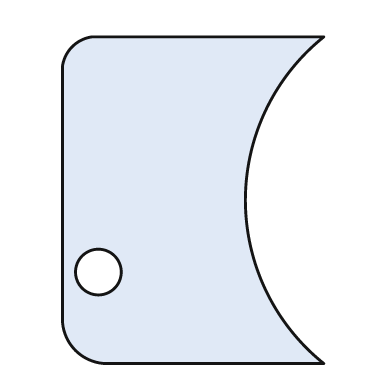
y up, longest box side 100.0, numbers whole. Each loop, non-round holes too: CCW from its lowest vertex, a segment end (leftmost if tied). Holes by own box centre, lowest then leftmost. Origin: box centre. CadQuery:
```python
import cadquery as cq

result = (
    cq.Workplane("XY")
    .moveTo(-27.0, -50.0)
    .lineTo(40.0, -50.0)
    .threePointArc((16.0, 0.0), (40.0, 50.0))
    .lineTo(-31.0, 50.0)
    .threePointArc((-37.0, 47.0), (-40.0, 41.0))
    .lineTo(-40.0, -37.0)
    .threePointArc((-36.0, -46.0), (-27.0, -50.0))
    .close()
    .moveTo(-29.0, -22.0)
    .circle(7.0)
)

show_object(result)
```